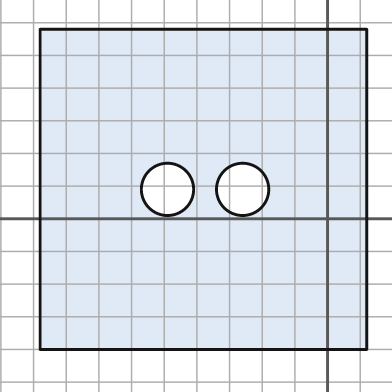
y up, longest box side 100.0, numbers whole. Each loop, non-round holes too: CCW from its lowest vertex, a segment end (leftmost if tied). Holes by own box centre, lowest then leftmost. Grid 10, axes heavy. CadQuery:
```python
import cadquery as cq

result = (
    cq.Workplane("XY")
    .moveTo(-88.0, -40.0)
    .lineTo(12.0, -40.0)
    .lineTo(12.0, 58.0)
    .lineTo(-88.0, 58.0)
    .close()
    .moveTo(-49.0, 9.0)
    .circle(8.0)
    .moveTo(-26.0, 9.0)
    .circle(8.0)
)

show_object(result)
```